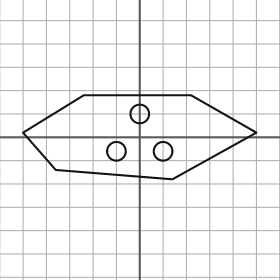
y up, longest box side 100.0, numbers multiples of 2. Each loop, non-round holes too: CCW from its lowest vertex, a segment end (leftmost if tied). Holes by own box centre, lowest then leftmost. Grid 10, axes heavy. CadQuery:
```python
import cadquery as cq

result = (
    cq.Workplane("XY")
    .moveTo(14.0, -18.0)
    .lineTo(50.0, 2.0)
    .lineTo(22.0, 18.0)
    .lineTo(-24.0, 18.0)
    .lineTo(-50.0, 2.0)
    .lineTo(-36.0, -14.0)
    .close()
    .moveTo(-10.0, -6.0)
    .circle(4.0)
    .moveTo(10.0, -6.0)
    .circle(4.0)
    .moveTo(0.0, 10.0)
    .circle(4.0)
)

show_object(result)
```